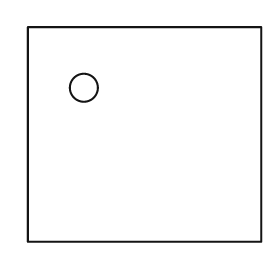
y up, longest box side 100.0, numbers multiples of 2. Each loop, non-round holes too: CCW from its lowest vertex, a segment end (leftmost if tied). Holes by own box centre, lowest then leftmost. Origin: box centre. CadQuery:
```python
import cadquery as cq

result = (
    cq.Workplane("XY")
    .moveTo(-50.0, -46.0)
    .lineTo(50.0, -46.0)
    .lineTo(50.0, 46.0)
    .lineTo(-50.0, 46.0)
    .close()
    .moveTo(-26.0, 20.0)
    .circle(6.0)
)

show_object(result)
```